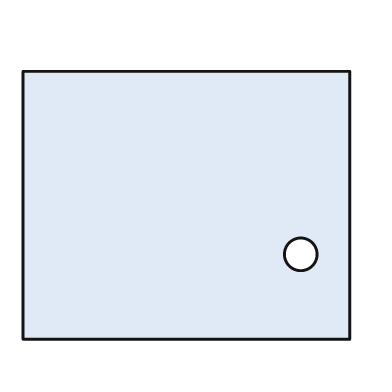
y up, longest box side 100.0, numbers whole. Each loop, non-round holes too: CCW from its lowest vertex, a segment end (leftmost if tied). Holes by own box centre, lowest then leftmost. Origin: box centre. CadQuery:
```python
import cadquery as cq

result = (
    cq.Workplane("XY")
    .moveTo(-50.0, -41.0)
    .lineTo(50.0, -41.0)
    .lineTo(50.0, 41.0)
    .lineTo(-50.0, 41.0)
    .close()
    .moveTo(35.0, -15.0)
    .circle(5.0)
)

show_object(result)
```